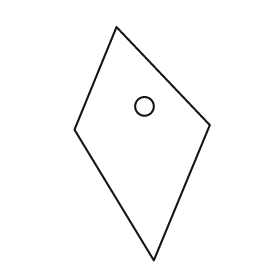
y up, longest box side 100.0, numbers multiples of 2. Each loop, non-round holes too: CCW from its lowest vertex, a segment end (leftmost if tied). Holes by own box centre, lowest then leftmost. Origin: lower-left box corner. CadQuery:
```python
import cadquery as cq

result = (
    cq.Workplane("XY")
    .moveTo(34.0, 0.0)
    .lineTo(58.0, 58.0)
    .lineTo(18.0, 100.0)
    .lineTo(0.0, 56.0)
    .close()
    .moveTo(30.0, 66.0)
    .circle(4.0)
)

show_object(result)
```